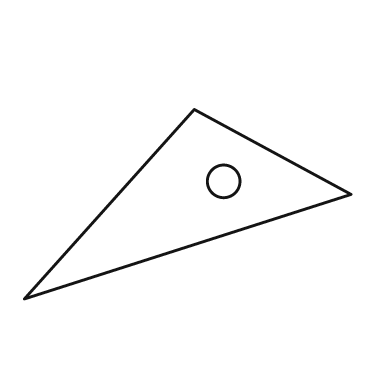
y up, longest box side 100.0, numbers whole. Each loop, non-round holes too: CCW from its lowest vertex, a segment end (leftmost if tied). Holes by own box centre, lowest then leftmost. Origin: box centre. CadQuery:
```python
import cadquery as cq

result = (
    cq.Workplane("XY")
    .moveTo(-50.0, -29.0)
    .lineTo(50.0, 3.0)
    .lineTo(2.0, 29.0)
    .close()
    .moveTo(11.0, 7.0)
    .circle(5.0)
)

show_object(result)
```